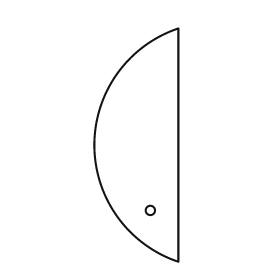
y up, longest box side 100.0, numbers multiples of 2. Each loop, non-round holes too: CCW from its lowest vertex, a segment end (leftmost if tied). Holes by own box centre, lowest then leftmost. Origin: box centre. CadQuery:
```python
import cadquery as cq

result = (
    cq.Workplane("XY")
    .moveTo(18.0, -50.0)
    .lineTo(18.0, 50.0)
    .threePointArc((-18.0, 0.0), (18.0, -50.0))
    .close()
    .moveTo(6.0, -28.0)
    .circle(2.0)
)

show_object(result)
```